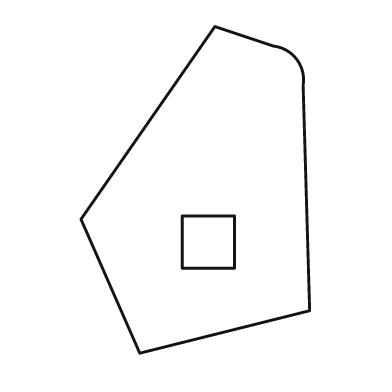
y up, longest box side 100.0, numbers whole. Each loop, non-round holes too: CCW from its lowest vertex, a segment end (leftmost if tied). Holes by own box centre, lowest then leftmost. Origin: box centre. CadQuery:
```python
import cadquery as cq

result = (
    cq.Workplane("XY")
    .moveTo(-17.0, -50.0)
    .lineTo(35.0, -37.0)
    .lineTo(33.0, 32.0)
    .threePointArc((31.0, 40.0), (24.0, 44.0))
    .lineTo(6.0, 50.0)
    .lineTo(-35.0, -9.0)
    .close()
    .moveTo(-4.0, -24.0)
    .lineTo(12.0, -24.0)
    .lineTo(12.0, -8.0)
    .lineTo(-4.0, -8.0)
    .close()
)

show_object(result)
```